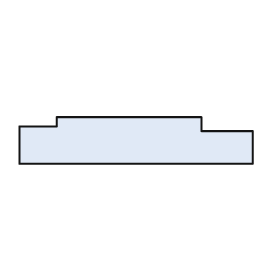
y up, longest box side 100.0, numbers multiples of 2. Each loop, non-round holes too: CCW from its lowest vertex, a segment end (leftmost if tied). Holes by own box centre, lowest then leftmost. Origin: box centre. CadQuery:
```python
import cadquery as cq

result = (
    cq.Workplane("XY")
    .moveTo(-50.0, -10.0)
    .lineTo(50.0, -10.0)
    .lineTo(50.0, 4.0)
    .lineTo(28.0, 4.0)
    .lineTo(28.0, 10.0)
    .lineTo(-34.0, 10.0)
    .lineTo(-34.0, 6.0)
    .lineTo(-50.0, 6.0)
    .close()
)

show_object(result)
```